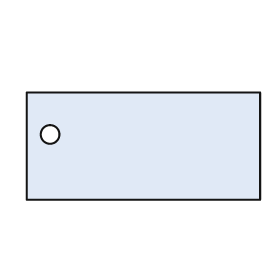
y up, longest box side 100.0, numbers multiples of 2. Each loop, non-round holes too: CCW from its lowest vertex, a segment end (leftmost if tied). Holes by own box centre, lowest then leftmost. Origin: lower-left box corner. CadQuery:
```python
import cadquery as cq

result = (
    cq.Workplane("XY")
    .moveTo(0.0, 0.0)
    .lineTo(100.0, 0.0)
    .lineTo(100.0, 46.0)
    .lineTo(0.0, 46.0)
    .close()
    .moveTo(10.0, 28.0)
    .circle(4.0)
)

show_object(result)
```